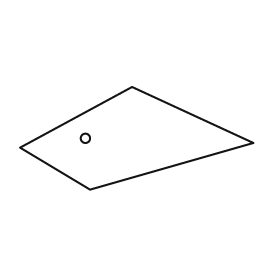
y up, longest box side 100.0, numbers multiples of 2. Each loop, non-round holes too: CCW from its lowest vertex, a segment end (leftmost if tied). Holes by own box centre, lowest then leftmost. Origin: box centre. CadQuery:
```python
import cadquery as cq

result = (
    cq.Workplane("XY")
    .moveTo(-20.0, -22.0)
    .lineTo(50.0, -2.0)
    .lineTo(-2.0, 22.0)
    .lineTo(-50.0, -4.0)
    .close()
    .moveTo(-22.0, 0.0)
    .circle(2.0)
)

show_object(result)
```